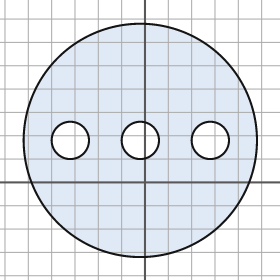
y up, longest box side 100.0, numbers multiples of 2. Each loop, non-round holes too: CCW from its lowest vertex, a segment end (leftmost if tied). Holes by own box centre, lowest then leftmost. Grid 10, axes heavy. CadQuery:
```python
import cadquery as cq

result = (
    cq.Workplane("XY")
    .moveTo(-2.0, 18.0)
    .circle(50.0)
    .moveTo(-32.0, 18.0)
    .circle(8.0)
    .moveTo(-2.0, 18.0)
    .circle(8.0)
    .moveTo(28.0, 18.0)
    .circle(8.0)
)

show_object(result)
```